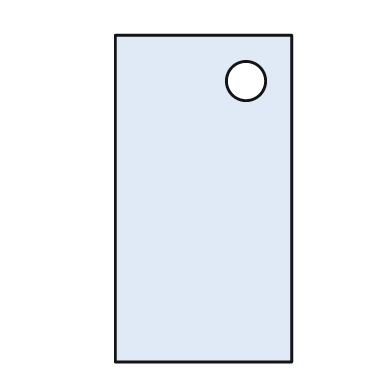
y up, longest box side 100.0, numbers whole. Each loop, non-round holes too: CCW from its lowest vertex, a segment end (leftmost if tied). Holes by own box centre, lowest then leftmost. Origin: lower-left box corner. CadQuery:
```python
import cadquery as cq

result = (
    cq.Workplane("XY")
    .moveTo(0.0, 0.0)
    .lineTo(54.0, 0.0)
    .lineTo(54.0, 100.0)
    .lineTo(0.0, 100.0)
    .close()
    .moveTo(40.0, 86.0)
    .circle(6.0)
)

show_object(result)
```